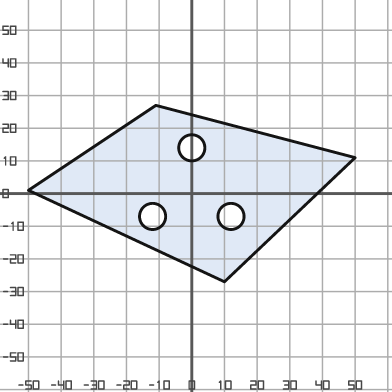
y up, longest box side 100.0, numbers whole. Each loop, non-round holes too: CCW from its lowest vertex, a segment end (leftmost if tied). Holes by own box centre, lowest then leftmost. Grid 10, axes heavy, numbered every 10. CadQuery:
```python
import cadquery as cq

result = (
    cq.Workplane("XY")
    .moveTo(10.0, -27.0)
    .lineTo(50.0, 11.0)
    .lineTo(-11.0, 27.0)
    .lineTo(-50.0, 1.0)
    .close()
    .moveTo(-12.0, -7.0)
    .circle(4.0)
    .moveTo(12.0, -7.0)
    .circle(4.0)
    .moveTo(0.0, 14.0)
    .circle(4.0)
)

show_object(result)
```